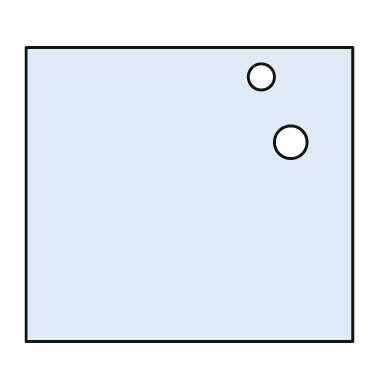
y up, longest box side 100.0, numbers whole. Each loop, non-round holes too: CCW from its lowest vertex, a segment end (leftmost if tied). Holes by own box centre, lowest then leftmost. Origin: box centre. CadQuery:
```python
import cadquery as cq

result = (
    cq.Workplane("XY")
    .moveTo(-50.0, -45.0)
    .lineTo(50.0, -45.0)
    .lineTo(50.0, 45.0)
    .lineTo(-50.0, 45.0)
    .close()
    .moveTo(31.0, 16.0)
    .circle(5.0)
    .moveTo(22.0, 36.0)
    .circle(4.0)
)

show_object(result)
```